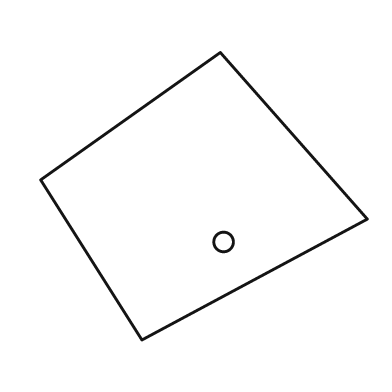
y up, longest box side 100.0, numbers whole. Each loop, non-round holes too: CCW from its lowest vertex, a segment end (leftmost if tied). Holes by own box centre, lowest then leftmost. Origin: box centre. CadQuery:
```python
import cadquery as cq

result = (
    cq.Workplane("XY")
    .moveTo(-19.0, -44.0)
    .lineTo(50.0, -7.0)
    .lineTo(5.0, 44.0)
    .lineTo(-50.0, 5.0)
    .close()
    .moveTo(6.0, -14.0)
    .circle(3.0)
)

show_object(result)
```